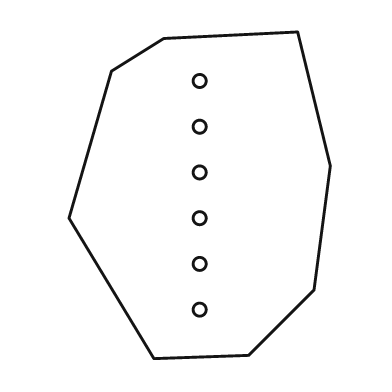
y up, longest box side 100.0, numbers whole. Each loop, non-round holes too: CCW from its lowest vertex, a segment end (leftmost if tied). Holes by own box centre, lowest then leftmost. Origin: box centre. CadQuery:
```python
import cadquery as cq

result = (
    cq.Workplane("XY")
    .moveTo(-14.0, -50.0)
    .lineTo(15.0, -49.0)
    .lineTo(35.0, -29.0)
    .lineTo(40.0, 9.0)
    .lineTo(30.0, 50.0)
    .lineTo(-11.0, 48.0)
    .lineTo(-27.0, 38.0)
    .lineTo(-40.0, -7.0)
    .close()
    .moveTo(0.0, -35.0)
    .circle(2.0)
    .moveTo(0.0, -21.0)
    .circle(2.0)
    .moveTo(0.0, -7.0)
    .circle(2.0)
    .moveTo(0.0, 7.0)
    .circle(2.0)
    .moveTo(0.0, 21.0)
    .circle(2.0)
    .moveTo(0.0, 35.0)
    .circle(2.0)
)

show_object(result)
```